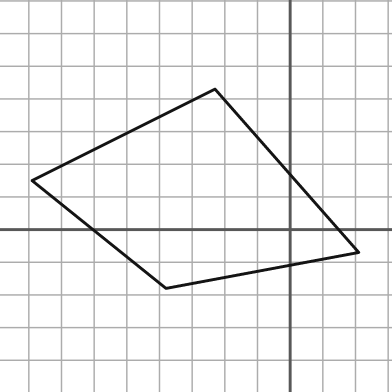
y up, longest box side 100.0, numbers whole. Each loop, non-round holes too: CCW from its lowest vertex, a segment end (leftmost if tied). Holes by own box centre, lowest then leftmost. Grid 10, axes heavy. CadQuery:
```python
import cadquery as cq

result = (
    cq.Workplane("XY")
    .moveTo(-38.0, -18.0)
    .lineTo(21.0, -7.0)
    .lineTo(-23.0, 43.0)
    .lineTo(-79.0, 15.0)
    .close()
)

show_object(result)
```